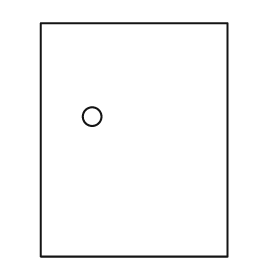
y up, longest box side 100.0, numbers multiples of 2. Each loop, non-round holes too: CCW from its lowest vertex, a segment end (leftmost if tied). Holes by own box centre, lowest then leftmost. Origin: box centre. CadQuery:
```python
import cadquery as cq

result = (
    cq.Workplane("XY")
    .moveTo(-40.0, -50.0)
    .lineTo(40.0, -50.0)
    .lineTo(40.0, 50.0)
    .lineTo(-40.0, 50.0)
    .close()
    .moveTo(-18.0, 10.0)
    .circle(4.0)
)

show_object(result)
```